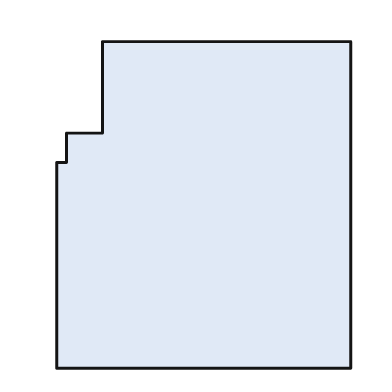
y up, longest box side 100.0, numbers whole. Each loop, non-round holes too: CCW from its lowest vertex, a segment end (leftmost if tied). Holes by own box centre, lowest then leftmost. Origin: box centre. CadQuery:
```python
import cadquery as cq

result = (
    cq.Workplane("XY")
    .moveTo(-45.0, -50.0)
    .lineTo(45.0, -50.0)
    .lineTo(45.0, 50.0)
    .lineTo(-31.0, 50.0)
    .lineTo(-31.0, 22.0)
    .lineTo(-42.0, 22.0)
    .lineTo(-42.0, 13.0)
    .lineTo(-45.0, 13.0)
    .close()
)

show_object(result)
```